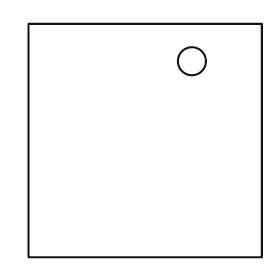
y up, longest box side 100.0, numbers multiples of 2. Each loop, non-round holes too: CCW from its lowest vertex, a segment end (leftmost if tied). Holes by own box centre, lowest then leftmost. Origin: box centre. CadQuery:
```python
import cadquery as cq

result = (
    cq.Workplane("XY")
    .moveTo(-50.0, -50.0)
    .lineTo(50.0, -50.0)
    .lineTo(50.0, 50.0)
    .lineTo(-50.0, 50.0)
    .close()
    .moveTo(20.0, 34.0)
    .circle(6.0)
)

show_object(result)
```